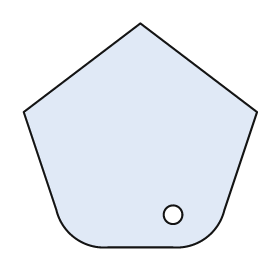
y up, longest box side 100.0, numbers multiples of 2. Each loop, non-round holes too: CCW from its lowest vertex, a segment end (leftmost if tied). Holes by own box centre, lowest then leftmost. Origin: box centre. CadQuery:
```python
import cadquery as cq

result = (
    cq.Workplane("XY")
    .moveTo(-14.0, -48.0)
    .lineTo(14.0, -48.0)
    .threePointArc((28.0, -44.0), (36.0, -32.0))
    .lineTo(50.0, 10.0)
    .lineTo(0.0, 48.0)
    .lineTo(-50.0, 10.0)
    .lineTo(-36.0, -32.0)
    .threePointArc((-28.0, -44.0), (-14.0, -48.0))
    .close()
    .moveTo(14.0, -34.0)
    .circle(4.0)
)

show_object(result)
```